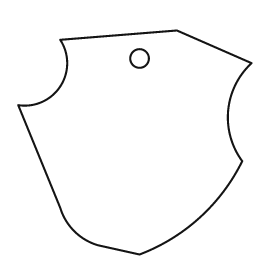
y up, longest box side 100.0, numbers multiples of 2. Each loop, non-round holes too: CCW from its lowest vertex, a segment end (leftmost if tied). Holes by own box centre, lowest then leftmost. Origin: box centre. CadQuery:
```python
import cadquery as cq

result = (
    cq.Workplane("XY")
    .moveTo(2.0, -48.0)
    .threePointArc((28.0, -32.0), (46.0, -8.0))
    .threePointArc((40.0, 14.0), (50.0, 34.0))
    .lineTo(18.0, 48.0)
    .lineTo(-32.0, 44.0)
    .threePointArc((-32.0, 24.0), (-50.0, 16.0))
    .lineTo(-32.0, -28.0)
    .threePointArc((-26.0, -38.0), (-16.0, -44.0))
    .close()
    .moveTo(2.0, 36.0)
    .circle(4.0)
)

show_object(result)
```